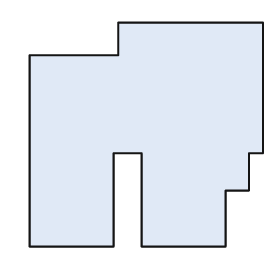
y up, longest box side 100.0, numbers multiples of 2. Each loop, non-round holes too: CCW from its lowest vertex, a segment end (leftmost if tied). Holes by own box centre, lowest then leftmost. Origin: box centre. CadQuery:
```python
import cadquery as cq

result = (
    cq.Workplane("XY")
    .moveTo(-50.0, -48.0)
    .lineTo(-14.0, -48.0)
    .lineTo(-14.0, -8.0)
    .lineTo(-2.0, -8.0)
    .lineTo(-2.0, -48.0)
    .lineTo(34.0, -48.0)
    .lineTo(34.0, -24.0)
    .lineTo(44.0, -24.0)
    .lineTo(44.0, -8.0)
    .lineTo(50.0, -8.0)
    .lineTo(50.0, 48.0)
    .lineTo(-12.0, 48.0)
    .lineTo(-12.0, 34.0)
    .lineTo(-50.0, 34.0)
    .close()
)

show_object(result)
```